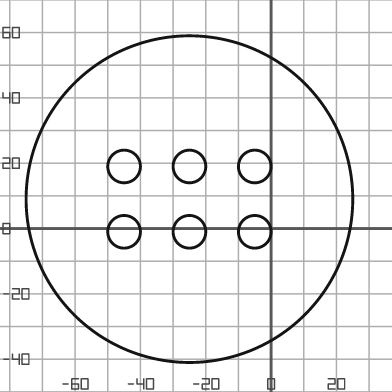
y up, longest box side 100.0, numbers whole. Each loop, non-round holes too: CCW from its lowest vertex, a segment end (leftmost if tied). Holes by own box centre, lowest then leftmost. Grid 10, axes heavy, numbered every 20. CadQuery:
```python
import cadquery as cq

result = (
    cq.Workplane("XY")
    .moveTo(-25.0, 9.0)
    .circle(50.0)
    .moveTo(-45.0, -1.0)
    .circle(5.0)
    .moveTo(-25.0, -1.0)
    .circle(5.0)
    .moveTo(-5.0, -1.0)
    .circle(5.0)
    .moveTo(-45.0, 19.0)
    .circle(5.0)
    .moveTo(-25.0, 19.0)
    .circle(5.0)
    .moveTo(-5.0, 19.0)
    .circle(5.0)
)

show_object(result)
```